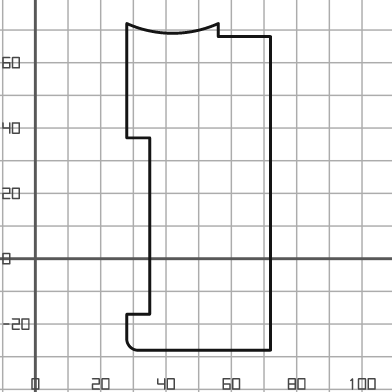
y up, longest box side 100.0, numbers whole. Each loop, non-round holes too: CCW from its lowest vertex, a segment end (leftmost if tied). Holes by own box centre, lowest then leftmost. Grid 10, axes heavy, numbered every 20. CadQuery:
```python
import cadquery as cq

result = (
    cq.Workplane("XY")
    .moveTo(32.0, -28.0)
    .lineTo(72.0, -28.0)
    .lineTo(72.0, 68.0)
    .lineTo(56.0, 68.0)
    .lineTo(56.0, 72.0)
    .threePointArc((42.0, 69.0), (28.0, 72.0))
    .lineTo(28.0, 37.0)
    .lineTo(35.0, 37.0)
    .lineTo(35.0, -17.0)
    .lineTo(28.0, -17.0)
    .lineTo(28.0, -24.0)
    .threePointArc((29.0, -27.0), (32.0, -28.0))
    .close()
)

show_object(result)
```